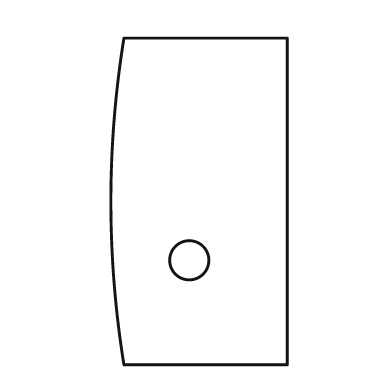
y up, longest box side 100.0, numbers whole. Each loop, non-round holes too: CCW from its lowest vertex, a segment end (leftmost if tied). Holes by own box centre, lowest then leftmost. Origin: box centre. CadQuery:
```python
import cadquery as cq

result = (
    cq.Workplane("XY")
    .moveTo(-23.0, -50.0)
    .lineTo(27.0, -50.0)
    .lineTo(27.0, 50.0)
    .lineTo(-23.0, 50.0)
    .threePointArc((-27.0, 0.0), (-23.0, -50.0))
    .close()
    .moveTo(-3.0, -18.0)
    .circle(6.0)
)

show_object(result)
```